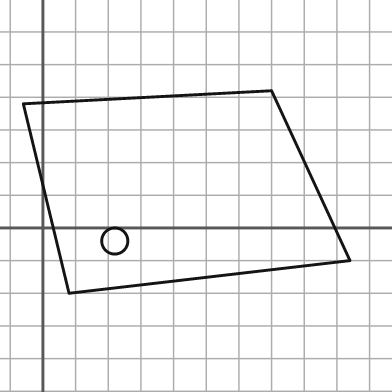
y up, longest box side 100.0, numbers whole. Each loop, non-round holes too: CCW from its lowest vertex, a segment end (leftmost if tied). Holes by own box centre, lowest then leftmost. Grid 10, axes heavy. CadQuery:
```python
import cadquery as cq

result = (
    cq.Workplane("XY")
    .moveTo(8.0, -20.0)
    .lineTo(94.0, -10.0)
    .lineTo(70.0, 42.0)
    .lineTo(-6.0, 38.0)
    .close()
    .moveTo(22.0, -4.0)
    .circle(4.0)
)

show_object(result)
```